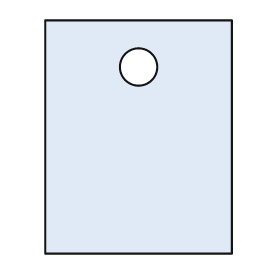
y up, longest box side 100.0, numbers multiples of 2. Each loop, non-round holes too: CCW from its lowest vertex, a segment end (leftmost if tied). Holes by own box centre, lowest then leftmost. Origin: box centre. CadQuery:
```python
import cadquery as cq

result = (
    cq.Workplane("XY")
    .moveTo(-40.0, -50.0)
    .lineTo(40.0, -50.0)
    .lineTo(40.0, 50.0)
    .lineTo(-40.0, 50.0)
    .close()
    .moveTo(0.0, 30.0)
    .circle(8.0)
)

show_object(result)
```